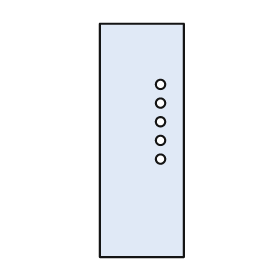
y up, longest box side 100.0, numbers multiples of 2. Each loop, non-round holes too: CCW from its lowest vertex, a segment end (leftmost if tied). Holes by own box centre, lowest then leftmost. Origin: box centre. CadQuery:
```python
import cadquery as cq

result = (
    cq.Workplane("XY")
    .moveTo(-18.0, -50.0)
    .lineTo(18.0, -50.0)
    .lineTo(18.0, 50.0)
    .lineTo(-18.0, 50.0)
    .close()
    .moveTo(8.0, -8.0)
    .circle(2.0)
    .moveTo(8.0, 0.0)
    .circle(2.0)
    .moveTo(8.0, 8.0)
    .circle(2.0)
    .moveTo(8.0, 16.0)
    .circle(2.0)
    .moveTo(8.0, 24.0)
    .circle(2.0)
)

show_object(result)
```